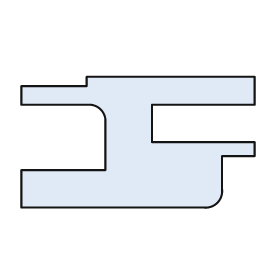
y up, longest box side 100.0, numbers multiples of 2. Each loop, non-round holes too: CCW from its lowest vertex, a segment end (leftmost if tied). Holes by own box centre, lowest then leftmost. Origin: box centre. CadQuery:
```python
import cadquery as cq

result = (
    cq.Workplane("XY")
    .moveTo(-50.0, -28.0)
    .lineTo(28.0, -28.0)
    .threePointArc((34.0, -26.0), (36.0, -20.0))
    .lineTo(36.0, -6.0)
    .lineTo(50.0, -6.0)
    .lineTo(50.0, 0.0)
    .lineTo(6.0, 0.0)
    .lineTo(6.0, 16.0)
    .lineTo(50.0, 16.0)
    .lineTo(50.0, 28.0)
    .lineTo(-22.0, 28.0)
    .lineTo(-22.0, 24.0)
    .lineTo(-50.0, 24.0)
    .lineTo(-50.0, 16.0)
    .lineTo(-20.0, 16.0)
    .threePointArc((-16.0, 14.0), (-14.0, 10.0))
    .lineTo(-14.0, -12.0)
    .lineTo(-50.0, -12.0)
    .close()
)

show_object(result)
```